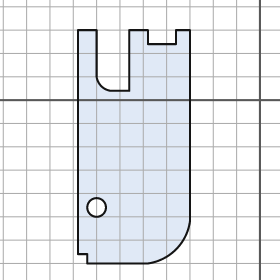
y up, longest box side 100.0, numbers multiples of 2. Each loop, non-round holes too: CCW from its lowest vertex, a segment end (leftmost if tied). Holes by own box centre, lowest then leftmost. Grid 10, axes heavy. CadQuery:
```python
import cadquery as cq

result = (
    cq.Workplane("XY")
    .moveTo(-74.0, -70.0)
    .lineTo(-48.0, -70.0)
    .threePointArc((-36.0, -64.0), (-30.0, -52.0))
    .lineTo(-30.0, 30.0)
    .lineTo(-36.0, 30.0)
    .lineTo(-36.0, 24.0)
    .lineTo(-48.0, 24.0)
    .lineTo(-48.0, 30.0)
    .lineTo(-56.0, 30.0)
    .lineTo(-56.0, 4.0)
    .lineTo(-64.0, 4.0)
    .threePointArc((-68.0, 6.0), (-70.0, 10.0))
    .lineTo(-70.0, 30.0)
    .lineTo(-78.0, 30.0)
    .lineTo(-78.0, -66.0)
    .lineTo(-74.0, -66.0)
    .close()
    .moveTo(-70.0, -46.0)
    .circle(4.0)
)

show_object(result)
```